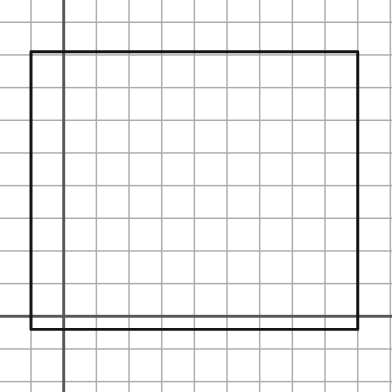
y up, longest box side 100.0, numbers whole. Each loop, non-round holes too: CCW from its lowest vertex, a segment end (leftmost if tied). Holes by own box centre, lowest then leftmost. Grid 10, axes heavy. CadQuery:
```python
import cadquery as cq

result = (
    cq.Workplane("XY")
    .moveTo(-10.0, -4.0)
    .lineTo(90.0, -4.0)
    .lineTo(90.0, 81.0)
    .lineTo(-10.0, 81.0)
    .close()
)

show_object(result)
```